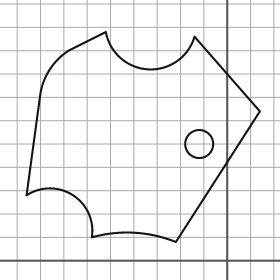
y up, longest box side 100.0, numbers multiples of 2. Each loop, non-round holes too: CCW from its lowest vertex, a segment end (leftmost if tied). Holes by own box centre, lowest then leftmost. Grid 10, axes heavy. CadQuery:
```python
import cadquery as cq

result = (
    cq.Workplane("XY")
    .moveTo(-22.0, 8.0)
    .lineTo(14.0, 64.0)
    .lineTo(-14.0, 96.0)
    .threePointArc((-34.0, 82.0), (-52.0, 98.0))
    .lineTo(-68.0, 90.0)
    .threePointArc((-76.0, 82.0), (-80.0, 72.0))
    .lineTo(-86.0, 28.0)
    .threePointArc((-66.0, 28.0), (-58.0, 10.0))
    .threePointArc((-40.0, 12.0), (-22.0, 8.0))
    .close()
    .moveTo(-12.0, 50.0)
    .circle(6.0)
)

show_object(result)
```